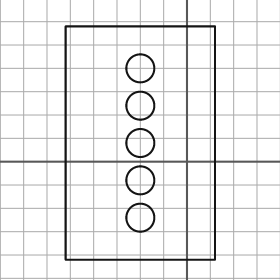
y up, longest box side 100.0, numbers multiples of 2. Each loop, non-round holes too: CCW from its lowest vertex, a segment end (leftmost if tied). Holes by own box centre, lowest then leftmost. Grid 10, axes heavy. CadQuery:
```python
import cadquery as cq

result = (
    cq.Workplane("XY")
    .moveTo(-52.0, -42.0)
    .lineTo(12.0, -42.0)
    .lineTo(12.0, 58.0)
    .lineTo(-52.0, 58.0)
    .close()
    .moveTo(-20.0, -24.0)
    .circle(6.0)
    .moveTo(-20.0, -8.0)
    .circle(6.0)
    .moveTo(-20.0, 8.0)
    .circle(6.0)
    .moveTo(-20.0, 24.0)
    .circle(6.0)
    .moveTo(-20.0, 40.0)
    .circle(6.0)
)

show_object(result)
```